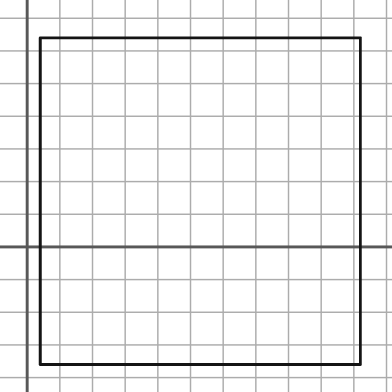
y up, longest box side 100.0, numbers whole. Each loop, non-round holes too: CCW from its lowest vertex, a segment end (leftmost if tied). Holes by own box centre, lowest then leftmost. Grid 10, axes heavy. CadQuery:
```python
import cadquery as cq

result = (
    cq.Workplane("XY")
    .moveTo(4.0, -36.0)
    .lineTo(102.0, -36.0)
    .lineTo(102.0, 64.0)
    .lineTo(4.0, 64.0)
    .close()
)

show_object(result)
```